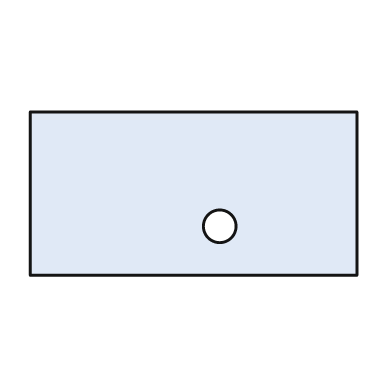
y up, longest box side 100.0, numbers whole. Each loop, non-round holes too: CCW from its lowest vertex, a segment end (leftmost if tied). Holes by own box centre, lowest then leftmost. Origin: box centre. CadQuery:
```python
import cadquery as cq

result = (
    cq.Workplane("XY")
    .moveTo(-50.0, -25.0)
    .lineTo(50.0, -25.0)
    .lineTo(50.0, 25.0)
    .lineTo(-50.0, 25.0)
    .close()
    .moveTo(8.0, -10.0)
    .circle(5.0)
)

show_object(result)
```